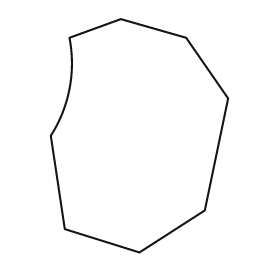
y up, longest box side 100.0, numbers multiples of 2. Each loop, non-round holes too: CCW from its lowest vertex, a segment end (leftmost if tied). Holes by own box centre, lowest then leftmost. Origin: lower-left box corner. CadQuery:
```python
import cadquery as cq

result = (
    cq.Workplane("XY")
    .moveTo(38.0, 0.0)
    .lineTo(66.0, 18.0)
    .lineTo(76.0, 66.0)
    .lineTo(58.0, 92.0)
    .lineTo(30.0, 100.0)
    .lineTo(8.0, 92.0)
    .threePointArc((8.0, 70.0), (0.0, 50.0))
    .lineTo(6.0, 10.0)
    .close()
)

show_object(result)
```